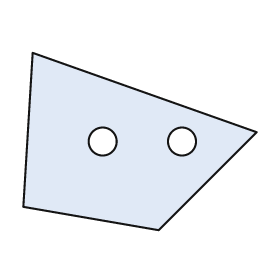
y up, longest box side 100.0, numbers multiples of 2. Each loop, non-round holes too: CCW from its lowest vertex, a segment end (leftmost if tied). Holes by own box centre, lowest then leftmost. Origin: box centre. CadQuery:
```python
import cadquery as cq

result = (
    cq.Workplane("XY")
    .moveTo(8.0, -38.0)
    .lineTo(50.0, 4.0)
    .lineTo(-46.0, 38.0)
    .lineTo(-50.0, -28.0)
    .close()
    .moveTo(-16.0, 0.0)
    .circle(6.0)
    .moveTo(18.0, 0.0)
    .circle(6.0)
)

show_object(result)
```